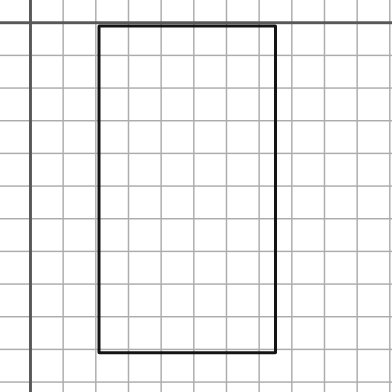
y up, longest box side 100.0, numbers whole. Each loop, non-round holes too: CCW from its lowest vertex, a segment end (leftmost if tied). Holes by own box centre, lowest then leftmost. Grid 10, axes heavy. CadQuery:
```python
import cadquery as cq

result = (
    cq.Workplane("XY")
    .moveTo(21.0, -101.0)
    .lineTo(75.0, -101.0)
    .lineTo(75.0, -1.0)
    .lineTo(21.0, -1.0)
    .close()
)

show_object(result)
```